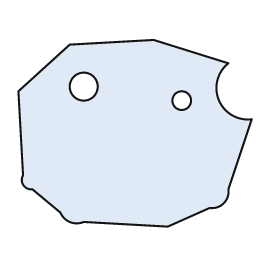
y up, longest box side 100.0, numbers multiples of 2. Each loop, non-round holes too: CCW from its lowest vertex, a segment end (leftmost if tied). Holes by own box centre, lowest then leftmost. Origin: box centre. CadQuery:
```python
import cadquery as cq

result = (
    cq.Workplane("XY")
    .moveTo(14.0, -40.0)
    .lineTo(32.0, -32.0)
    .threePointArc((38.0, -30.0), (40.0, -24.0))
    .lineTo(50.0, 6.0)
    .threePointArc((36.0, 14.0), (40.0, 30.0))
    .lineTo(8.0, 40.0)
    .lineTo(-28.0, 38.0)
    .lineTo(-50.0, 18.0)
    .lineTo(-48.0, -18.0)
    .threePointArc((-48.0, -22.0), (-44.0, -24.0))
    .lineTo(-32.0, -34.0)
    .threePointArc((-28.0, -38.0), (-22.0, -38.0))
    .close()
    .moveTo(20.0, 14.0)
    .circle(4.0)
    .moveTo(-22.0, 20.0)
    .circle(6.0)
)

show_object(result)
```